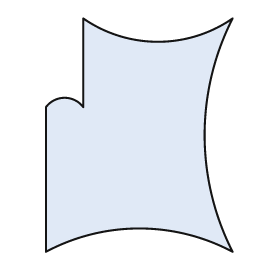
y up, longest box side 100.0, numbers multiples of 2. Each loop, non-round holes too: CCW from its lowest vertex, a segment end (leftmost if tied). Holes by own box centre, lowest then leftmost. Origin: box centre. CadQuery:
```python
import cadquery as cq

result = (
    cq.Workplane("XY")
    .moveTo(-40.0, -50.0)
    .threePointArc((0.0, -40.0), (40.0, -50.0))
    .threePointArc((28.0, 0.0), (40.0, 50.0))
    .threePointArc((8.0, 40.0), (-24.0, 50.0))
    .lineTo(-24.0, 12.0)
    .threePointArc((-32.0, 16.0), (-40.0, 12.0))
    .close()
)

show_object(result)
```